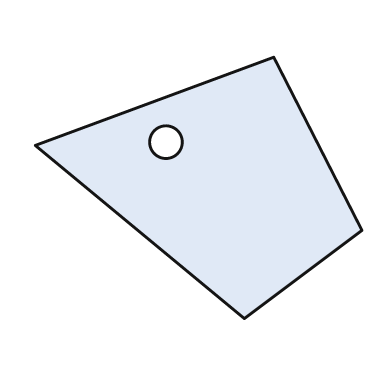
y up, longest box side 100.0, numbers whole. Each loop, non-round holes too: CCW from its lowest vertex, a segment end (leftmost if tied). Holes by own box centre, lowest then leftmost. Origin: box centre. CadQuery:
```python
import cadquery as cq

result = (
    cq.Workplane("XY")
    .moveTo(14.0, -40.0)
    .lineTo(50.0, -13.0)
    .lineTo(23.0, 40.0)
    .lineTo(-50.0, 13.0)
    .close()
    .moveTo(-10.0, 14.0)
    .circle(5.0)
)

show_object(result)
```